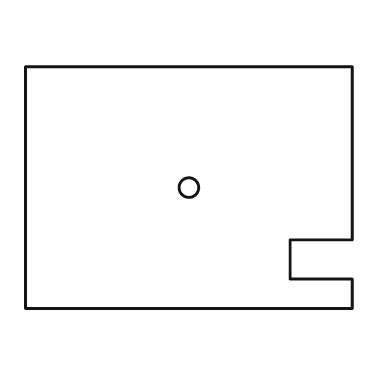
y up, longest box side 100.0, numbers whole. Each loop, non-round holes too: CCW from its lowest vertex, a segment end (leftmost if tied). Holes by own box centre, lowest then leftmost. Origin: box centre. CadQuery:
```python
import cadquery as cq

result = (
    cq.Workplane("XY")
    .moveTo(-50.0, -37.0)
    .lineTo(50.0, -37.0)
    .lineTo(50.0, -28.0)
    .lineTo(31.0, -28.0)
    .lineTo(31.0, -16.0)
    .lineTo(50.0, -16.0)
    .lineTo(50.0, 37.0)
    .lineTo(-50.0, 37.0)
    .close()
    .moveTo(0.0, 0.0)
    .circle(3.0)
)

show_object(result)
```